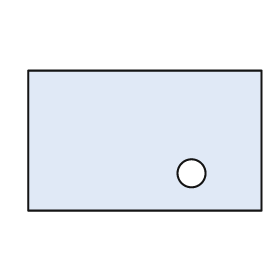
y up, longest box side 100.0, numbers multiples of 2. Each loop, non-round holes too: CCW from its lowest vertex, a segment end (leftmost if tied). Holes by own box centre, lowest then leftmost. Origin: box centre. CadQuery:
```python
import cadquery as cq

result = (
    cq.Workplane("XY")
    .moveTo(-50.0, -30.0)
    .lineTo(50.0, -30.0)
    .lineTo(50.0, 30.0)
    .lineTo(-50.0, 30.0)
    .close()
    .moveTo(20.0, -14.0)
    .circle(6.0)
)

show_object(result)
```